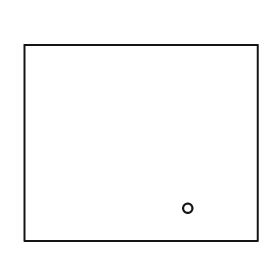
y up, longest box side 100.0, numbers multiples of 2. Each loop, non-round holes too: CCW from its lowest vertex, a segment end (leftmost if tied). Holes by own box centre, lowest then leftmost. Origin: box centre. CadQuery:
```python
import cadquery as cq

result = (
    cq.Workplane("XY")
    .moveTo(-50.0, -42.0)
    .lineTo(50.0, -42.0)
    .lineTo(50.0, 42.0)
    .lineTo(-50.0, 42.0)
    .close()
    .moveTo(20.0, -28.0)
    .circle(2.0)
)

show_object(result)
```